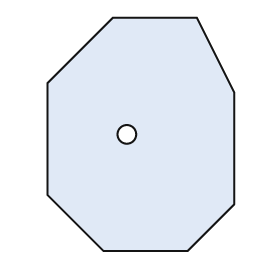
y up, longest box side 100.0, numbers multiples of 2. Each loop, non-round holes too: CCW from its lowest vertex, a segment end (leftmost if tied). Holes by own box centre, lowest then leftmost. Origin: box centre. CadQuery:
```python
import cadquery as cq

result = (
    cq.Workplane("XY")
    .moveTo(-16.0, -50.0)
    .lineTo(20.0, -50.0)
    .lineTo(40.0, -30.0)
    .lineTo(40.0, 18.0)
    .lineTo(24.0, 50.0)
    .lineTo(-12.0, 50.0)
    .lineTo(-40.0, 22.0)
    .lineTo(-40.0, -26.0)
    .close()
    .moveTo(-6.0, 0.0)
    .circle(4.0)
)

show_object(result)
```